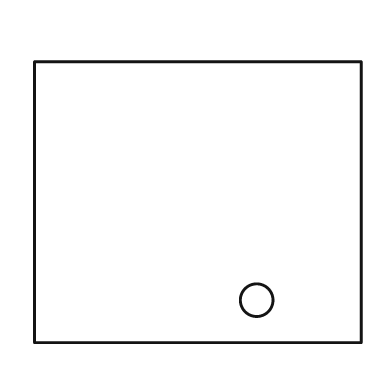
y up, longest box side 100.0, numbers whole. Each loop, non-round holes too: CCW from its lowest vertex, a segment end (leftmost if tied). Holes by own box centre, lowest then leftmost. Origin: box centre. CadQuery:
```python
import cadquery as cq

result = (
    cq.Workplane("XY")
    .moveTo(-50.0, -43.0)
    .lineTo(50.0, -43.0)
    .lineTo(50.0, 43.0)
    .lineTo(-50.0, 43.0)
    .close()
    .moveTo(18.0, -30.0)
    .circle(5.0)
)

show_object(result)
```